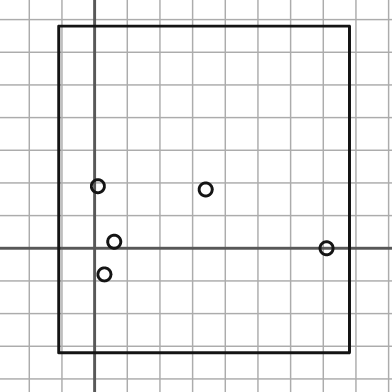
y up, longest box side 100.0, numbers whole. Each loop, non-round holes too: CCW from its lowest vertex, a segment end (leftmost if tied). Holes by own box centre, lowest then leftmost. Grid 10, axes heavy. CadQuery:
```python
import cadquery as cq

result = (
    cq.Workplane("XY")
    .moveTo(-11.0, -32.0)
    .lineTo(78.0, -32.0)
    .lineTo(78.0, 68.0)
    .lineTo(-11.0, 68.0)
    .close()
    .moveTo(3.0, -8.0)
    .circle(2.0)
    .moveTo(71.0, 0.0)
    .circle(2.0)
    .moveTo(6.0, 2.0)
    .circle(2.0)
    .moveTo(34.0, 18.0)
    .circle(2.0)
    .moveTo(1.0, 19.0)
    .circle(2.0)
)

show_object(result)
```